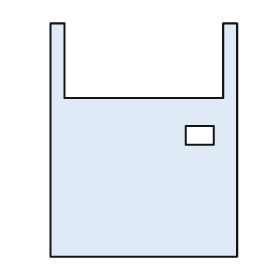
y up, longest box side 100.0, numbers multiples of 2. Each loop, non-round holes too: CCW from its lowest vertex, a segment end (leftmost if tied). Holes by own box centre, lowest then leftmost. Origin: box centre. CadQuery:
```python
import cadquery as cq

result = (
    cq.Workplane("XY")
    .moveTo(-40.0, -50.0)
    .lineTo(40.0, -50.0)
    .lineTo(40.0, 50.0)
    .lineTo(34.0, 50.0)
    .lineTo(34.0, 18.0)
    .lineTo(-34.0, 18.0)
    .lineTo(-34.0, 50.0)
    .lineTo(-40.0, 50.0)
    .close()
    .moveTo(18.0, -2.0)
    .lineTo(30.0, -2.0)
    .lineTo(30.0, 6.0)
    .lineTo(18.0, 6.0)
    .close()
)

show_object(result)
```